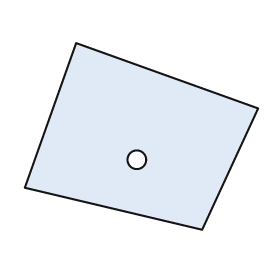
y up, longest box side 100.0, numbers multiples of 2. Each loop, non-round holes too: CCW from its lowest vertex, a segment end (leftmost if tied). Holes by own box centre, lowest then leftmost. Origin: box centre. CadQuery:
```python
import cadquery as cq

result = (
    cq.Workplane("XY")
    .moveTo(26.0, -40.0)
    .lineTo(50.0, 12.0)
    .lineTo(-28.0, 40.0)
    .lineTo(-50.0, -22.0)
    .close()
    .moveTo(-2.0, -10.0)
    .circle(4.0)
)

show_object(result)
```